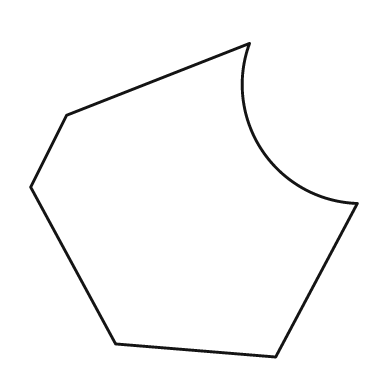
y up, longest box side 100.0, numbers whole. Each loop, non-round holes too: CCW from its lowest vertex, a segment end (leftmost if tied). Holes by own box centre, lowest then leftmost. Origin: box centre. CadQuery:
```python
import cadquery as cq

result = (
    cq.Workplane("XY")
    .moveTo(25.0, -48.0)
    .lineTo(50.0, -1.0)
    .threePointArc((21.0, 15.0), (17.0, 48.0))
    .lineTo(-39.0, 26.0)
    .lineTo(-50.0, 4.0)
    .lineTo(-24.0, -44.0)
    .close()
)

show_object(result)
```